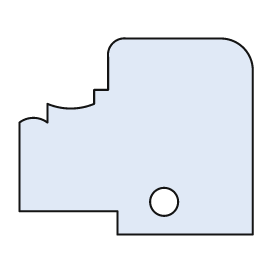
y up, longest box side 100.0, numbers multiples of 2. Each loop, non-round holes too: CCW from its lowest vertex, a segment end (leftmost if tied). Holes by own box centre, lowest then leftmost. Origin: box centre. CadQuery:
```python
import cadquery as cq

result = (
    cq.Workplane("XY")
    .moveTo(-8.0, -42.0)
    .lineTo(50.0, -42.0)
    .lineTo(50.0, 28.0)
    .threePointArc((46.0, 38.0), (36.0, 42.0))
    .lineTo(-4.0, 42.0)
    .threePointArc((-10.0, 40.0), (-12.0, 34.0))
    .lineTo(-12.0, 20.0)
    .lineTo(-18.0, 20.0)
    .lineTo(-18.0, 14.0)
    .threePointArc((-28.0, 12.0), (-38.0, 14.0))
    .lineTo(-38.0, 6.0)
    .threePointArc((-44.0, 8.0), (-50.0, 6.0))
    .lineTo(-50.0, -32.0)
    .lineTo(-8.0, -32.0)
    .close()
    .moveTo(12.0, -28.0)
    .circle(6.0)
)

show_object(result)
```